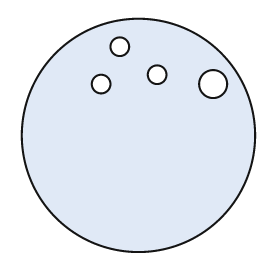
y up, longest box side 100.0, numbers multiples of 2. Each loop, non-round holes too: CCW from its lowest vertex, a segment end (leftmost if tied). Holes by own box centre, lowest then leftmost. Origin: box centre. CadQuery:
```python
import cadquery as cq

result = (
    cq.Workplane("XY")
    .moveTo(0.0, 0.0)
    .circle(50.0)
    .moveTo(-16.0, 22.0)
    .circle(4.0)
    .moveTo(32.0, 22.0)
    .circle(6.0)
    .moveTo(8.0, 26.0)
    .circle(4.0)
    .moveTo(-8.0, 38.0)
    .circle(4.0)
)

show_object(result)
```